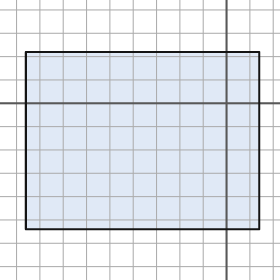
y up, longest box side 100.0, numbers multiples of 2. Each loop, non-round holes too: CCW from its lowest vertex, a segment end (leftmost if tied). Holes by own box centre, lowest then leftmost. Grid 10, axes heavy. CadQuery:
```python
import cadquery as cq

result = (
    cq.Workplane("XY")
    .moveTo(-86.0, -54.0)
    .lineTo(14.0, -54.0)
    .lineTo(14.0, 22.0)
    .lineTo(-86.0, 22.0)
    .close()
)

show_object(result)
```